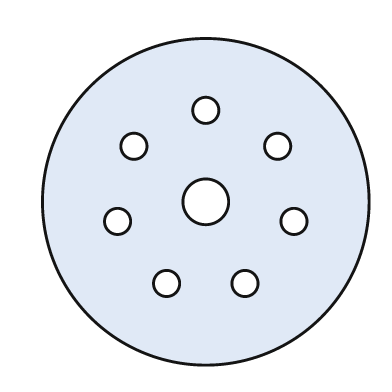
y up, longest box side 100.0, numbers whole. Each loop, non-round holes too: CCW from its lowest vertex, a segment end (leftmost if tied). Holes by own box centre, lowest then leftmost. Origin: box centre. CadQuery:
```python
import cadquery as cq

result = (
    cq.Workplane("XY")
    .moveTo(0.0, 0.0)
    .circle(50.0)
    .moveTo(-12.0, -25.0)
    .circle(4.0)
    .moveTo(12.0, -25.0)
    .circle(4.0)
    .moveTo(-27.0, -6.0)
    .circle(4.0)
    .moveTo(27.0, -6.0)
    .circle(4.0)
    .moveTo(0.0, 0.0)
    .circle(7.0)
    .moveTo(-22.0, 17.0)
    .circle(4.0)
    .moveTo(22.0, 17.0)
    .circle(4.0)
    .moveTo(0.0, 28.0)
    .circle(4.0)
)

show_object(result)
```